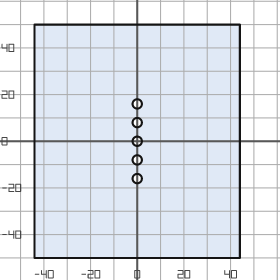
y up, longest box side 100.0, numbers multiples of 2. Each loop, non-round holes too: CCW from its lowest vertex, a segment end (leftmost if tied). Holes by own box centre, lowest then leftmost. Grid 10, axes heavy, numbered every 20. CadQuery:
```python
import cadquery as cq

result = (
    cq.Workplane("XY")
    .moveTo(-44.0, -50.0)
    .lineTo(44.0, -50.0)
    .lineTo(44.0, 50.0)
    .lineTo(-44.0, 50.0)
    .close()
    .moveTo(0.0, -16.0)
    .circle(2.0)
    .moveTo(0.0, -8.0)
    .circle(2.0)
    .moveTo(0.0, 0.0)
    .circle(2.0)
    .moveTo(0.0, 8.0)
    .circle(2.0)
    .moveTo(0.0, 16.0)
    .circle(2.0)
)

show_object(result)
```